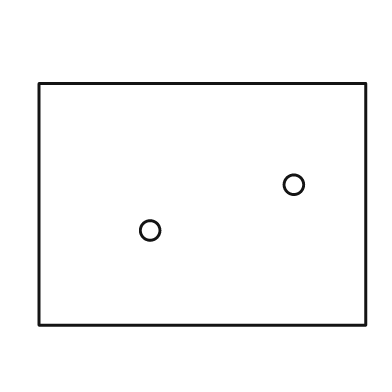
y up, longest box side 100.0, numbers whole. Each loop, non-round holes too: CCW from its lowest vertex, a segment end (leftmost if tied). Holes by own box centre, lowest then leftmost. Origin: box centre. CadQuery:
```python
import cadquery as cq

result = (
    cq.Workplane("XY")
    .moveTo(-50.0, -37.0)
    .lineTo(50.0, -37.0)
    .lineTo(50.0, 37.0)
    .lineTo(-50.0, 37.0)
    .close()
    .moveTo(-16.0, -8.0)
    .circle(3.0)
    .moveTo(28.0, 6.0)
    .circle(3.0)
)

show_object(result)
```